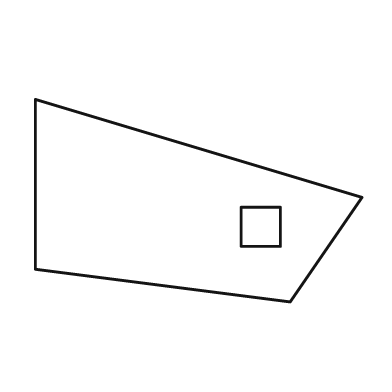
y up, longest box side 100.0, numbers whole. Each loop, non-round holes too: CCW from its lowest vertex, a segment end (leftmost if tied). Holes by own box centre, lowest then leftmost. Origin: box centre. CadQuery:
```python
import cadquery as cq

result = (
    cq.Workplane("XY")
    .moveTo(28.0, -31.0)
    .lineTo(50.0, 1.0)
    .lineTo(-50.0, 31.0)
    .lineTo(-50.0, -21.0)
    .close()
    .moveTo(13.0, -14.0)
    .lineTo(25.0, -14.0)
    .lineTo(25.0, -2.0)
    .lineTo(13.0, -2.0)
    .close()
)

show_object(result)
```